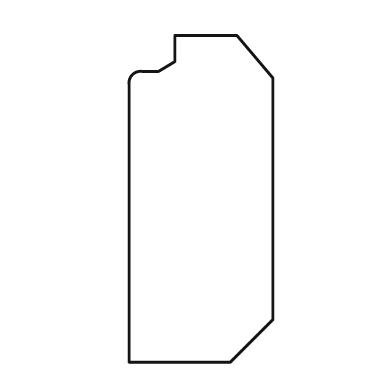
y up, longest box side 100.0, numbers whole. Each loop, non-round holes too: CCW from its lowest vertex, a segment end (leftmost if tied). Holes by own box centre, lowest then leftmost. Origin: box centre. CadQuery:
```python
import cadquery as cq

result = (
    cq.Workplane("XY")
    .moveTo(-22.0, -50.0)
    .lineTo(9.0, -50.0)
    .lineTo(22.0, -37.0)
    .lineTo(22.0, 37.0)
    .lineTo(11.0, 50.0)
    .lineTo(-8.0, 50.0)
    .lineTo(-8.0, 42.0)
    .lineTo(-13.0, 39.0)
    .lineTo(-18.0, 39.0)
    .threePointArc((-21.0, 38.0), (-22.0, 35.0))
    .close()
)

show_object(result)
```